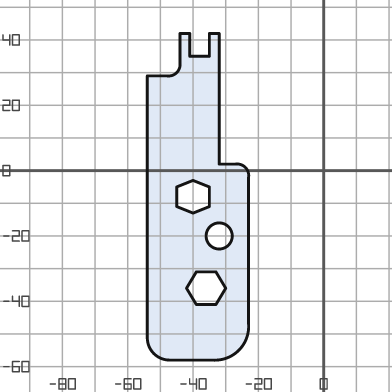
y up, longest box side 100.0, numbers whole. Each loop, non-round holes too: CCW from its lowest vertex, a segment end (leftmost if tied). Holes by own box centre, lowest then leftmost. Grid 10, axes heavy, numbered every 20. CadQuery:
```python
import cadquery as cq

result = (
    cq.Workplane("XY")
    .moveTo(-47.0, -58.0)
    .lineTo(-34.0, -58.0)
    .threePointArc((-26.0, -55.0), (-23.0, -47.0))
    .lineTo(-23.0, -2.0)
    .threePointArc((-24.0, 1.0), (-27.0, 2.0))
    .lineTo(-32.0, 2.0)
    .lineTo(-32.0, 42.0)
    .lineTo(-35.0, 42.0)
    .lineTo(-35.0, 35.0)
    .lineTo(-41.0, 35.0)
    .lineTo(-41.0, 42.0)
    .lineTo(-44.0, 42.0)
    .lineTo(-44.0, 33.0)
    .threePointArc((-45.0, 30.0), (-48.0, 29.0))
    .lineTo(-54.0, 29.0)
    .lineTo(-54.0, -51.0)
    .threePointArc((-52.0, -56.0), (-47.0, -58.0))
    .close()
    .moveTo(-39.0, -41.0)
    .lineTo(-33.0, -41.0)
    .lineTo(-30.0, -36.0)
    .lineTo(-33.0, -31.0)
    .lineTo(-39.0, -31.0)
    .lineTo(-42.0, -36.0)
    .close()
    .moveTo(-32.0, -20.0)
    .circle(4.0)
    .moveTo(-40.0, -13.0)
    .lineTo(-35.0, -11.0)
    .lineTo(-35.0, -5.0)
    .lineTo(-40.0, -3.0)
    .lineTo(-45.0, -5.0)
    .lineTo(-45.0, -11.0)
    .close()
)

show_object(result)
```